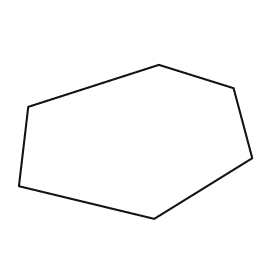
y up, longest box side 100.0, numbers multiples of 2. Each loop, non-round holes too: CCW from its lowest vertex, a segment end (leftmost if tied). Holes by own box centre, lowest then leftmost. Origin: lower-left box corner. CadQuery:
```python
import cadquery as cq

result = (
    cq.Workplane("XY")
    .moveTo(58.0, 0.0)
    .lineTo(100.0, 26.0)
    .lineTo(92.0, 56.0)
    .lineTo(60.0, 66.0)
    .lineTo(4.0, 48.0)
    .lineTo(0.0, 14.0)
    .close()
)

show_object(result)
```